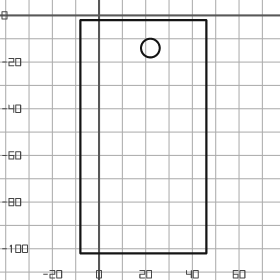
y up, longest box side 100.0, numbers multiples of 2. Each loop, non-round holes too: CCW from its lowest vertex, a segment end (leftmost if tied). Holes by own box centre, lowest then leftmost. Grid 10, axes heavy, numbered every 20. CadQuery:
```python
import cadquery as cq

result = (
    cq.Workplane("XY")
    .moveTo(-8.0, -102.0)
    .lineTo(46.0, -102.0)
    .lineTo(46.0, -2.0)
    .lineTo(-8.0, -2.0)
    .close()
    .moveTo(22.0, -14.0)
    .circle(4.0)
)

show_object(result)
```